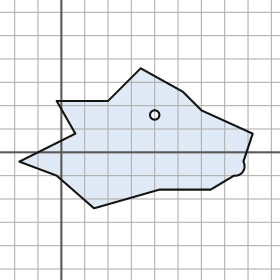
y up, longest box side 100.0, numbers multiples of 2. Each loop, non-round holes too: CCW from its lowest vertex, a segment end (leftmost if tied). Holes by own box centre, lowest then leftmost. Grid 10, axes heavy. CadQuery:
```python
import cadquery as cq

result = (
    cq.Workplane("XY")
    .moveTo(14.0, -24.0)
    .lineTo(42.0, -16.0)
    .lineTo(64.0, -16.0)
    .lineTo(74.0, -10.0)
    .threePointArc((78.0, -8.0), (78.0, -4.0))
    .lineTo(82.0, 8.0)
    .lineTo(60.0, 18.0)
    .lineTo(52.0, 26.0)
    .lineTo(34.0, 36.0)
    .lineTo(20.0, 22.0)
    .lineTo(-2.0, 22.0)
    .lineTo(6.0, 8.0)
    .lineTo(-18.0, -4.0)
    .lineTo(-2.0, -10.0)
    .close()
    .moveTo(40.0, 16.0)
    .circle(2.0)
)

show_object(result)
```